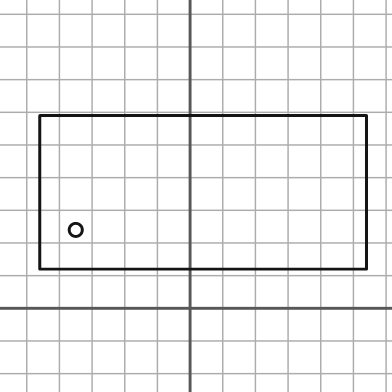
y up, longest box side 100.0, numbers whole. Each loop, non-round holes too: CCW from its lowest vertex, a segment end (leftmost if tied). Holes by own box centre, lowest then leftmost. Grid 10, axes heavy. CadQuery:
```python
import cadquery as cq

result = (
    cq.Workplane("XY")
    .moveTo(-46.0, 12.0)
    .lineTo(54.0, 12.0)
    .lineTo(54.0, 59.0)
    .lineTo(-46.0, 59.0)
    .close()
    .moveTo(-35.0, 24.0)
    .circle(2.0)
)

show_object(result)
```